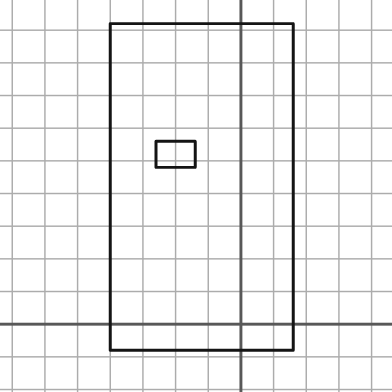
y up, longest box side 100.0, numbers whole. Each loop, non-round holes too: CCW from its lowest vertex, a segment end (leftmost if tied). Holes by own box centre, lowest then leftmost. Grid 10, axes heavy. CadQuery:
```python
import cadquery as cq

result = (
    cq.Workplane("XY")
    .moveTo(-40.0, -8.0)
    .lineTo(16.0, -8.0)
    .lineTo(16.0, 92.0)
    .lineTo(-40.0, 92.0)
    .close()
    .moveTo(-26.0, 48.0)
    .lineTo(-14.0, 48.0)
    .lineTo(-14.0, 56.0)
    .lineTo(-26.0, 56.0)
    .close()
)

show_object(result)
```